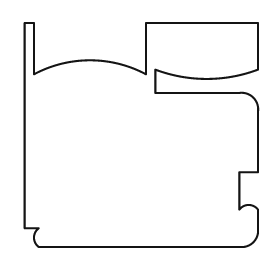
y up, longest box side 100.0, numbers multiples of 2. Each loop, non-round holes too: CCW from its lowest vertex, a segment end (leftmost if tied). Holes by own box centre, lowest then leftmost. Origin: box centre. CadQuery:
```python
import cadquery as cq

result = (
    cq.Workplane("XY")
    .moveTo(-44.0, -48.0)
    .lineTo(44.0, -48.0)
    .threePointArc((48.0, -46.0), (50.0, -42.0))
    .lineTo(50.0, -32.0)
    .threePointArc((46.0, -30.0), (42.0, -32.0))
    .lineTo(42.0, -16.0)
    .lineTo(50.0, -16.0)
    .lineTo(50.0, 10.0)
    .threePointArc((48.0, 16.0), (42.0, 18.0))
    .lineTo(6.0, 18.0)
    .lineTo(6.0, 28.0)
    .threePointArc((28.0, 24.0), (50.0, 28.0))
    .lineTo(50.0, 48.0)
    .lineTo(2.0, 48.0)
    .lineTo(2.0, 26.0)
    .threePointArc((-22.0, 32.0), (-46.0, 26.0))
    .lineTo(-46.0, 48.0)
    .lineTo(-50.0, 48.0)
    .lineTo(-50.0, -40.0)
    .lineTo(-44.0, -40.0)
    .threePointArc((-46.0, -44.0), (-44.0, -48.0))
    .close()
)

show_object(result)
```